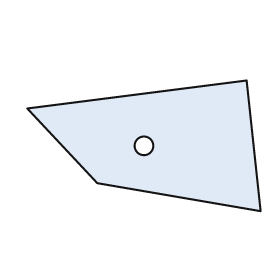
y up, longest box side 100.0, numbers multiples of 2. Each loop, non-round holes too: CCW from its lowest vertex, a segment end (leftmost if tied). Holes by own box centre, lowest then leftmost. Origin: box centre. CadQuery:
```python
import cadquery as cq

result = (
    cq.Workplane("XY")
    .moveTo(50.0, -28.0)
    .lineTo(44.0, 28.0)
    .lineTo(-50.0, 16.0)
    .lineTo(-20.0, -16.0)
    .close()
    .moveTo(0.0, 0.0)
    .circle(4.0)
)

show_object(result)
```